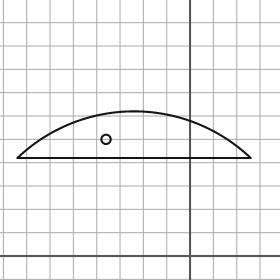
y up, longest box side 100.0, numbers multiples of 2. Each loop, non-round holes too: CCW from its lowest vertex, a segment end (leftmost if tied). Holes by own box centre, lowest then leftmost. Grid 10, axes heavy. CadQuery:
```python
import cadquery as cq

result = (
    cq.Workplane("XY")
    .moveTo(-74.0, 42.0)
    .lineTo(26.0, 42.0)
    .threePointArc((-24.0, 62.0), (-74.0, 42.0))
    .close()
    .moveTo(-36.0, 50.0)
    .circle(2.0)
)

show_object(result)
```